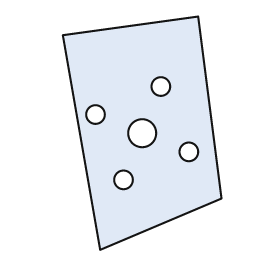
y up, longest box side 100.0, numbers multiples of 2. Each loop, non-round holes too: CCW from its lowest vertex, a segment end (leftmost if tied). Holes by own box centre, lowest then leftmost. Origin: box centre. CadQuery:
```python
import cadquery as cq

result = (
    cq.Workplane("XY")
    .moveTo(-18.0, -50.0)
    .lineTo(34.0, -28.0)
    .lineTo(24.0, 50.0)
    .lineTo(-34.0, 42.0)
    .close()
    .moveTo(-8.0, -20.0)
    .circle(4.0)
    .moveTo(20.0, -8.0)
    .circle(4.0)
    .moveTo(0.0, 0.0)
    .circle(6.0)
    .moveTo(-20.0, 8.0)
    .circle(4.0)
    .moveTo(8.0, 20.0)
    .circle(4.0)
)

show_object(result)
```